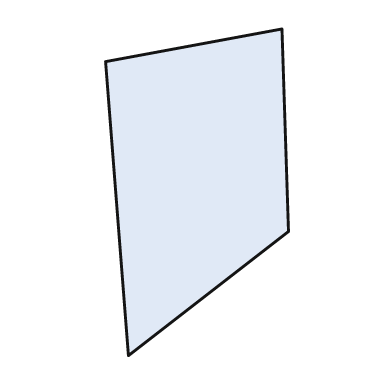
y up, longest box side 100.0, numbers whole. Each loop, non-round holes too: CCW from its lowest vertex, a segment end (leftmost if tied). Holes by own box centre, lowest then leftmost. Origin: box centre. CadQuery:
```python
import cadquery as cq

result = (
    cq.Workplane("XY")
    .moveTo(-21.0, -50.0)
    .lineTo(28.0, -12.0)
    .lineTo(26.0, 50.0)
    .lineTo(-28.0, 40.0)
    .close()
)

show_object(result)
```